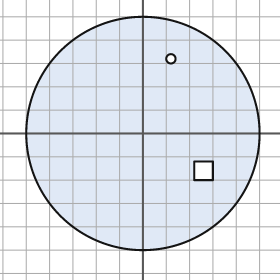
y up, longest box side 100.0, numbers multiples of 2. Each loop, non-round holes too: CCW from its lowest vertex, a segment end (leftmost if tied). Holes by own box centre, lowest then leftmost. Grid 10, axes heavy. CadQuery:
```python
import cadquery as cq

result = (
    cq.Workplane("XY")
    .moveTo(0.0, 0.0)
    .circle(50.0)
    .moveTo(22.0, -20.0)
    .lineTo(30.0, -20.0)
    .lineTo(30.0, -12.0)
    .lineTo(22.0, -12.0)
    .close()
    .moveTo(12.0, 32.0)
    .circle(2.0)
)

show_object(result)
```